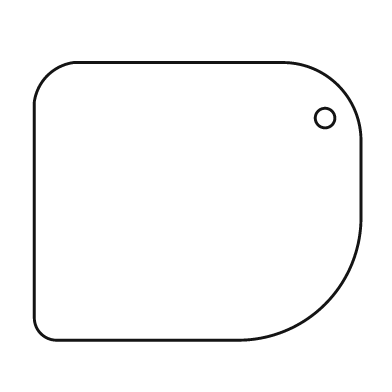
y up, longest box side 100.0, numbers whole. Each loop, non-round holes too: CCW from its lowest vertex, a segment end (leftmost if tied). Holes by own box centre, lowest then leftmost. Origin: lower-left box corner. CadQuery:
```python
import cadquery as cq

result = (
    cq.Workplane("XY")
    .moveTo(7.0, 0.0)
    .lineTo(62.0, 0.0)
    .threePointArc((89.0, 11.0), (100.0, 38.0))
    .lineTo(100.0, 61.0)
    .threePointArc((93.0, 78.0), (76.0, 85.0))
    .lineTo(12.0, 85.0)
    .threePointArc((4.0, 81.0), (0.0, 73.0))
    .lineTo(0.0, 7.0)
    .threePointArc((2.0, 2.0), (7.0, 0.0))
    .close()
    .moveTo(89.0, 68.0)
    .circle(3.0)
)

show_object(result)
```